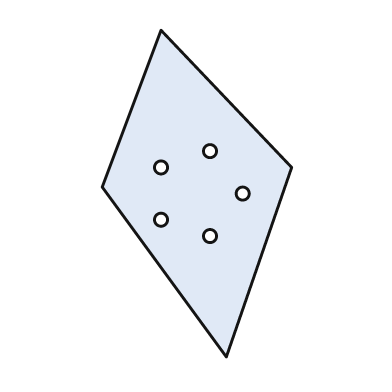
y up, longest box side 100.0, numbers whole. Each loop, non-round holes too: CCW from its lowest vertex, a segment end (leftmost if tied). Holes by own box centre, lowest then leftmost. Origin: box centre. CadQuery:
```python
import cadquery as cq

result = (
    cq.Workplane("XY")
    .moveTo(9.0, -50.0)
    .lineTo(29.0, 8.0)
    .lineTo(-11.0, 50.0)
    .lineTo(-29.0, 2.0)
    .close()
    .moveTo(4.0, -13.0)
    .circle(2.0)
    .moveTo(-11.0, -8.0)
    .circle(2.0)
    .moveTo(14.0, 0.0)
    .circle(2.0)
    .moveTo(-11.0, 8.0)
    .circle(2.0)
    .moveTo(4.0, 13.0)
    .circle(2.0)
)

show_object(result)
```